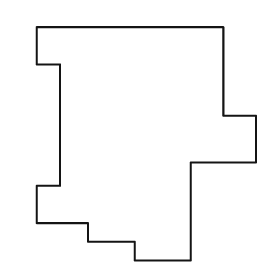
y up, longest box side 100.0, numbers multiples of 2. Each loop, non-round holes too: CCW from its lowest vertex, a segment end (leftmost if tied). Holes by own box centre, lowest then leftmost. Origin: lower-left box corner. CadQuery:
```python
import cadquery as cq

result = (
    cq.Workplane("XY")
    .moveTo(42.0, 0.0)
    .lineTo(66.0, 0.0)
    .lineTo(66.0, 42.0)
    .lineTo(94.0, 42.0)
    .lineTo(94.0, 62.0)
    .lineTo(80.0, 62.0)
    .lineTo(80.0, 100.0)
    .lineTo(0.0, 100.0)
    .lineTo(0.0, 84.0)
    .lineTo(10.0, 84.0)
    .lineTo(10.0, 32.0)
    .lineTo(0.0, 32.0)
    .lineTo(0.0, 16.0)
    .lineTo(22.0, 16.0)
    .lineTo(22.0, 8.0)
    .lineTo(42.0, 8.0)
    .close()
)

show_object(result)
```